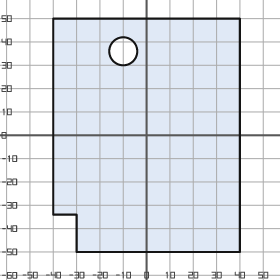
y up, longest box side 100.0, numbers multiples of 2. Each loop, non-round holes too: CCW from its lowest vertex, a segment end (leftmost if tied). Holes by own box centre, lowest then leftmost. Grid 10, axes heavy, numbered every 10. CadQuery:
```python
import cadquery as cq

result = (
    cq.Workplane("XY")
    .moveTo(-30.0, -50.0)
    .lineTo(40.0, -50.0)
    .lineTo(40.0, 50.0)
    .lineTo(-40.0, 50.0)
    .lineTo(-40.0, -34.0)
    .lineTo(-30.0, -34.0)
    .close()
    .moveTo(-10.0, 36.0)
    .circle(6.0)
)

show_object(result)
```